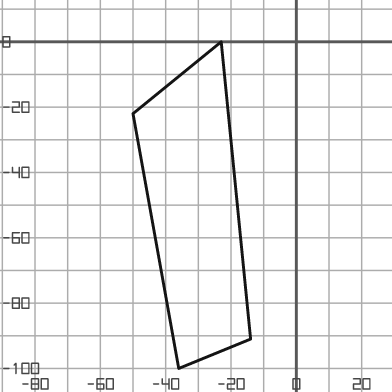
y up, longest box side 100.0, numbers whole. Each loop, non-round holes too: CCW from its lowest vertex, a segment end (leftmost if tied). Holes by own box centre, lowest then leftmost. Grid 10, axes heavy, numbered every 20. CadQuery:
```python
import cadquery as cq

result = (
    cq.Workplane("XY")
    .moveTo(-36.0, -100.0)
    .lineTo(-14.0, -91.0)
    .lineTo(-23.0, 0.0)
    .lineTo(-50.0, -22.0)
    .close()
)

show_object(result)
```